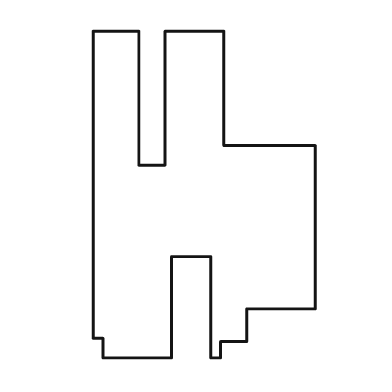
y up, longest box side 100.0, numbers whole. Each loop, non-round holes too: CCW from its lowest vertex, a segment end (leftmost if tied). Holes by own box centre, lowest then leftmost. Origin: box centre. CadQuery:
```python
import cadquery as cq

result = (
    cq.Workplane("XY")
    .moveTo(-31.0, -50.0)
    .lineTo(-10.0, -50.0)
    .lineTo(-10.0, -19.0)
    .lineTo(2.0, -19.0)
    .lineTo(2.0, -50.0)
    .lineTo(5.0, -50.0)
    .lineTo(5.0, -45.0)
    .lineTo(13.0, -45.0)
    .lineTo(13.0, -35.0)
    .lineTo(34.0, -35.0)
    .lineTo(34.0, 15.0)
    .lineTo(6.0, 15.0)
    .lineTo(6.0, 50.0)
    .lineTo(-12.0, 50.0)
    .lineTo(-12.0, 9.0)
    .lineTo(-20.0, 9.0)
    .lineTo(-20.0, 50.0)
    .lineTo(-34.0, 50.0)
    .lineTo(-34.0, -44.0)
    .lineTo(-31.0, -44.0)
    .close()
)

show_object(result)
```